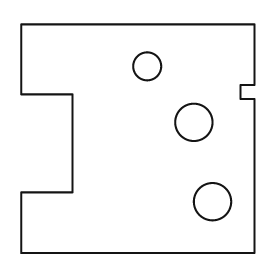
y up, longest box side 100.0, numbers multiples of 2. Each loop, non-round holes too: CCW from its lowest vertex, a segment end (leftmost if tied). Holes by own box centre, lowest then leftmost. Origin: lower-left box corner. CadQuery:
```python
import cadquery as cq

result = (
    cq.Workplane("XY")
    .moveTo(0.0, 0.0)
    .lineTo(100.0, 0.0)
    .lineTo(100.0, 66.0)
    .lineTo(94.0, 66.0)
    .lineTo(94.0, 72.0)
    .lineTo(100.0, 72.0)
    .lineTo(100.0, 98.0)
    .lineTo(0.0, 98.0)
    .lineTo(0.0, 68.0)
    .lineTo(22.0, 68.0)
    .lineTo(22.0, 26.0)
    .lineTo(0.0, 26.0)
    .close()
    .moveTo(82.0, 22.0)
    .circle(8.0)
    .moveTo(74.0, 56.0)
    .circle(8.0)
    .moveTo(54.0, 80.0)
    .circle(6.0)
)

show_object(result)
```